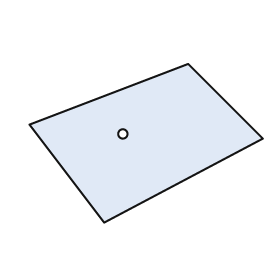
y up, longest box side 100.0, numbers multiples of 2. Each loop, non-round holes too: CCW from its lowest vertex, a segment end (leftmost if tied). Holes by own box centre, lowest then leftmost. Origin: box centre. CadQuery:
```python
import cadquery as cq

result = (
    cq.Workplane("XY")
    .moveTo(-18.0, -34.0)
    .lineTo(50.0, 2.0)
    .lineTo(18.0, 34.0)
    .lineTo(-50.0, 8.0)
    .close()
    .moveTo(-10.0, 4.0)
    .circle(2.0)
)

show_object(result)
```